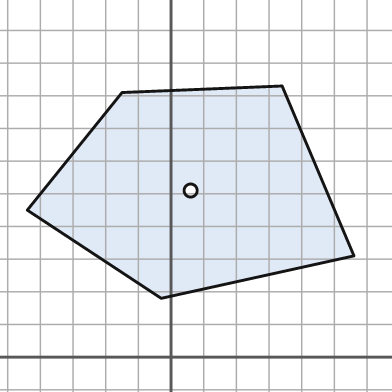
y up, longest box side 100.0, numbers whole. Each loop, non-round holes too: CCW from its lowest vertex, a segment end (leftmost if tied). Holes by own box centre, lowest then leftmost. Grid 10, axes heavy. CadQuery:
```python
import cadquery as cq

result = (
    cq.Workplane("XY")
    .moveTo(-3.0, 18.0)
    .lineTo(56.0, 31.0)
    .lineTo(34.0, 83.0)
    .lineTo(-15.0, 81.0)
    .lineTo(-44.0, 45.0)
    .close()
    .moveTo(6.0, 51.0)
    .circle(2.0)
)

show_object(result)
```